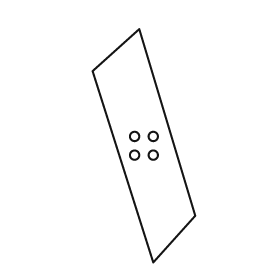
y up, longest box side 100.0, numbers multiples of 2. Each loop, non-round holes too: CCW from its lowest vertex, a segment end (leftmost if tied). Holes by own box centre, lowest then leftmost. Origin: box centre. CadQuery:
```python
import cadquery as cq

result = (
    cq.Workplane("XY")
    .moveTo(4.0, -50.0)
    .lineTo(22.0, -30.0)
    .lineTo(-2.0, 50.0)
    .lineTo(-22.0, 32.0)
    .close()
    .moveTo(-4.0, -4.0)
    .circle(2.0)
    .moveTo(4.0, -4.0)
    .circle(2.0)
    .moveTo(-4.0, 4.0)
    .circle(2.0)
    .moveTo(4.0, 4.0)
    .circle(2.0)
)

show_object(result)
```